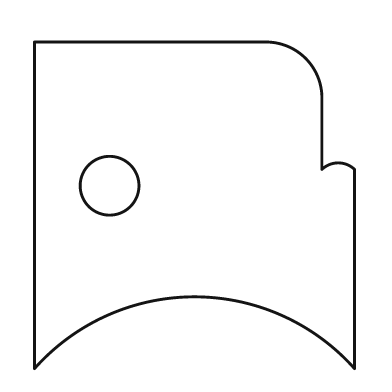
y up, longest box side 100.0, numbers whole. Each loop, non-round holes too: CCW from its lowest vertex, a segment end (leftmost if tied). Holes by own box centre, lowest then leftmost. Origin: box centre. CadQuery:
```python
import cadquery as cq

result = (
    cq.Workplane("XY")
    .moveTo(-49.0, -50.0)
    .threePointArc((0.0, -28.0), (49.0, -50.0))
    .lineTo(49.0, 11.0)
    .threePointArc((44.0, 13.0), (39.0, 11.0))
    .lineTo(39.0, 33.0)
    .threePointArc((34.0, 45.0), (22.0, 50.0))
    .lineTo(-49.0, 50.0)
    .close()
    .moveTo(-26.0, 6.0)
    .circle(9.0)
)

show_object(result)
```